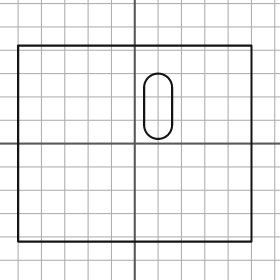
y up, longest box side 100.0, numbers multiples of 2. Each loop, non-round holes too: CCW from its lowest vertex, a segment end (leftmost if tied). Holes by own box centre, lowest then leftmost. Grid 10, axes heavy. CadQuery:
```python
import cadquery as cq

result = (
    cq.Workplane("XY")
    .moveTo(-50.0, -42.0)
    .lineTo(50.0, -42.0)
    .lineTo(50.0, 42.0)
    .lineTo(-50.0, 42.0)
    .close()
    .moveTo(4.0, 8.0)
    .threePointArc((10.0, 2.0), (16.0, 8.0))
    .lineTo(16.0, 24.0)
    .threePointArc((10.0, 30.0), (4.0, 24.0))
    .close()
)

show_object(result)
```